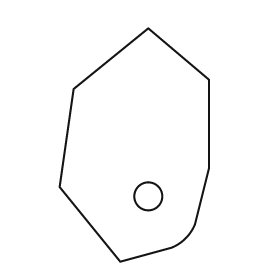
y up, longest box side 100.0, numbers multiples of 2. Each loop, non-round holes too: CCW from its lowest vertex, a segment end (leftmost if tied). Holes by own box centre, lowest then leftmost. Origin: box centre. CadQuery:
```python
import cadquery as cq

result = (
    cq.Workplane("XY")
    .moveTo(-6.0, -50.0)
    .lineTo(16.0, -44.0)
    .threePointArc((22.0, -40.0), (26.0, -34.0))
    .lineTo(32.0, -10.0)
    .lineTo(32.0, 28.0)
    .lineTo(6.0, 50.0)
    .lineTo(-26.0, 24.0)
    .lineTo(-32.0, -18.0)
    .close()
    .moveTo(6.0, -22.0)
    .circle(6.0)
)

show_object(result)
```